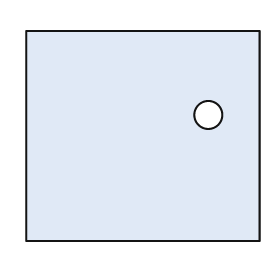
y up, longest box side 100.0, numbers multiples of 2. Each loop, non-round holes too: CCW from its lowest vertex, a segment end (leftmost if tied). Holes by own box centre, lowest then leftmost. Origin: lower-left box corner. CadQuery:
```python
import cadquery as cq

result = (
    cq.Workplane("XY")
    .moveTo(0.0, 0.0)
    .lineTo(100.0, 0.0)
    .lineTo(100.0, 90.0)
    .lineTo(0.0, 90.0)
    .close()
    .moveTo(78.0, 54.0)
    .circle(6.0)
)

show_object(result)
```